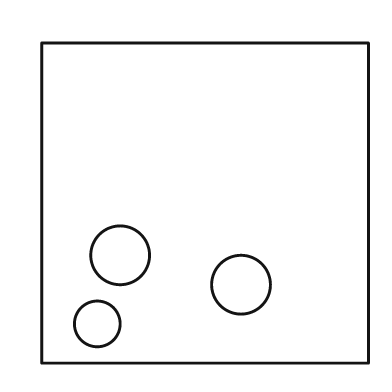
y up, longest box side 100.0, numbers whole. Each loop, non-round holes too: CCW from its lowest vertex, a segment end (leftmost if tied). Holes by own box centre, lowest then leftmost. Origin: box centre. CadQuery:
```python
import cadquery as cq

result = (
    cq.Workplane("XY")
    .moveTo(-50.0, -49.0)
    .lineTo(50.0, -49.0)
    .lineTo(50.0, 49.0)
    .lineTo(-50.0, 49.0)
    .close()
    .moveTo(-33.0, -37.0)
    .circle(7.0)
    .moveTo(11.0, -25.0)
    .circle(9.0)
    .moveTo(-26.0, -16.0)
    .circle(9.0)
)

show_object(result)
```